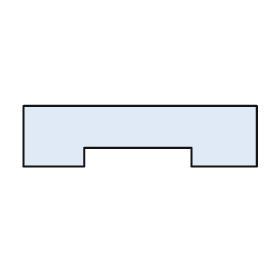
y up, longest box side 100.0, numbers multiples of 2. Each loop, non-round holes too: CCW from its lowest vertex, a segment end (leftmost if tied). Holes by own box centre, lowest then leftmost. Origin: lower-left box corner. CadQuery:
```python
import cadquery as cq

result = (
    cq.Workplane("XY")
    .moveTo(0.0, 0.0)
    .lineTo(26.0, 0.0)
    .lineTo(26.0, 8.0)
    .lineTo(72.0, 8.0)
    .lineTo(72.0, 0.0)
    .lineTo(100.0, 0.0)
    .lineTo(100.0, 26.0)
    .lineTo(0.0, 26.0)
    .close()
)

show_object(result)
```